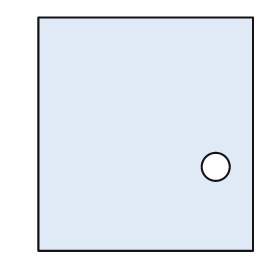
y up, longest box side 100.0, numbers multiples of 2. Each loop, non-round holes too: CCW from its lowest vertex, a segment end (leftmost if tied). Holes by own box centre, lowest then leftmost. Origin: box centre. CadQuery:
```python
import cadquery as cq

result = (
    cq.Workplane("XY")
    .moveTo(-46.0, -50.0)
    .lineTo(46.0, -50.0)
    .lineTo(46.0, 50.0)
    .lineTo(-46.0, 50.0)
    .close()
    .moveTo(30.0, -14.0)
    .circle(6.0)
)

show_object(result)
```